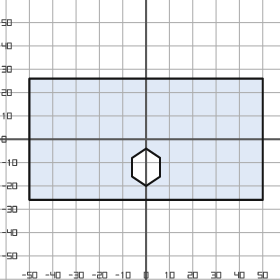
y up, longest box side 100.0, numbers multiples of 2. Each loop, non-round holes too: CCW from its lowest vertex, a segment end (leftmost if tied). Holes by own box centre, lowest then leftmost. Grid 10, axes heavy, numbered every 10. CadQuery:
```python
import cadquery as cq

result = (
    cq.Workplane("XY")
    .moveTo(-50.0, -26.0)
    .lineTo(50.0, -26.0)
    .lineTo(50.0, 26.0)
    .lineTo(-50.0, 26.0)
    .close()
    .moveTo(0.0, -20.0)
    .lineTo(6.0, -16.0)
    .lineTo(6.0, -8.0)
    .lineTo(0.0, -4.0)
    .lineTo(-6.0, -8.0)
    .lineTo(-6.0, -16.0)
    .close()
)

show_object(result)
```